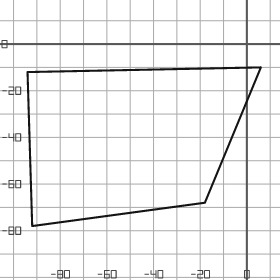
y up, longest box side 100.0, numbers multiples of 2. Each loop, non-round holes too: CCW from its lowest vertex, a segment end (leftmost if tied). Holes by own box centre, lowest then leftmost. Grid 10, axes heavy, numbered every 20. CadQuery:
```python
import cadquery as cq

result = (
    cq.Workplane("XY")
    .moveTo(-92.0, -78.0)
    .lineTo(-18.0, -68.0)
    .lineTo(6.0, -10.0)
    .lineTo(-94.0, -12.0)
    .close()
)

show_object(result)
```